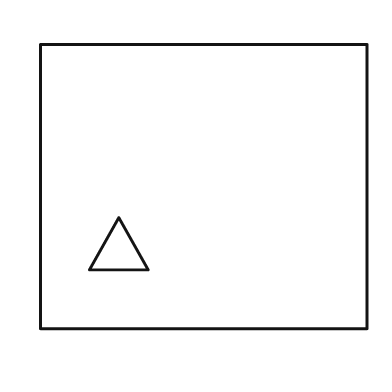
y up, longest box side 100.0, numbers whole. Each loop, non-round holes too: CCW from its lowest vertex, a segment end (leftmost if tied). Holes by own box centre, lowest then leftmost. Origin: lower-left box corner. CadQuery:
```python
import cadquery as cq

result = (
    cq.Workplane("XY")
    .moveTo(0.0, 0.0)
    .lineTo(100.0, 0.0)
    .lineTo(100.0, 87.0)
    .lineTo(0.0, 87.0)
    .close()
    .moveTo(15.0, 18.0)
    .lineTo(33.0, 18.0)
    .lineTo(24.0, 34.0)
    .close()
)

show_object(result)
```